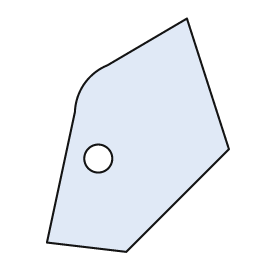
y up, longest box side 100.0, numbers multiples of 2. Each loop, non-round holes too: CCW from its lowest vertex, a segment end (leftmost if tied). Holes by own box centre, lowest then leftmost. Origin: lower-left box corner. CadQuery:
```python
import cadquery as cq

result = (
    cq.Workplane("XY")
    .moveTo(34.0, 0.0)
    .lineTo(78.0, 44.0)
    .lineTo(60.0, 100.0)
    .lineTo(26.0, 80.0)
    .threePointArc((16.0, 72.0), (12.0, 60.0))
    .lineTo(0.0, 4.0)
    .close()
    .moveTo(22.0, 40.0)
    .circle(6.0)
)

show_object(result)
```